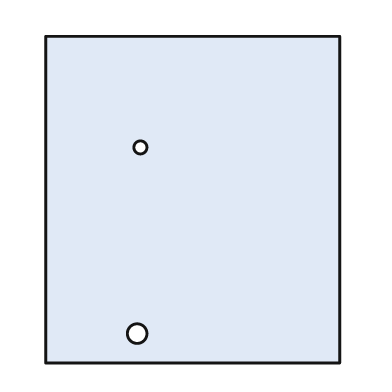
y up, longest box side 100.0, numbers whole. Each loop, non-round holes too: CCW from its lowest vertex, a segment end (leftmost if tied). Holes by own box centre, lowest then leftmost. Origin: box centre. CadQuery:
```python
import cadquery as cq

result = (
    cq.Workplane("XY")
    .moveTo(-45.0, -50.0)
    .lineTo(45.0, -50.0)
    .lineTo(45.0, 50.0)
    .lineTo(-45.0, 50.0)
    .close()
    .moveTo(-17.0, -41.0)
    .circle(3.0)
    .moveTo(-16.0, 16.0)
    .circle(2.0)
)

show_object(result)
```